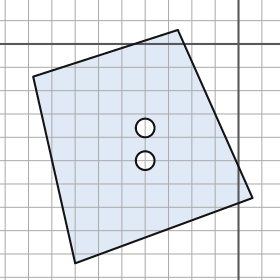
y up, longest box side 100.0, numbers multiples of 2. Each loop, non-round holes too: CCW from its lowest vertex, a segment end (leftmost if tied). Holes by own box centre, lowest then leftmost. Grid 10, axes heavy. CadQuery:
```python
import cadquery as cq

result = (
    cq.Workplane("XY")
    .moveTo(-70.0, -94.0)
    .lineTo(6.0, -66.0)
    .lineTo(-26.0, 6.0)
    .lineTo(-88.0, -14.0)
    .close()
    .moveTo(-40.0, -50.0)
    .circle(4.0)
    .moveTo(-40.0, -36.0)
    .circle(4.0)
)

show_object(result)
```